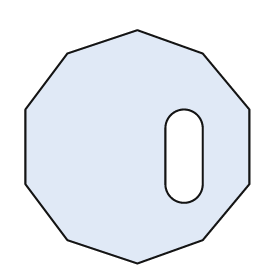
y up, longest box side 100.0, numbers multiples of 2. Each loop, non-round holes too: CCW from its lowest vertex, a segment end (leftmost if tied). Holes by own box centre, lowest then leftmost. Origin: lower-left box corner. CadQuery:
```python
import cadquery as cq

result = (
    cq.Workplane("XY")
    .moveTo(48.0, 0.0)
    .lineTo(76.0, 10.0)
    .lineTo(96.0, 34.0)
    .lineTo(96.0, 66.0)
    .lineTo(76.0, 90.0)
    .lineTo(48.0, 100.0)
    .lineTo(18.0, 90.0)
    .lineTo(0.0, 66.0)
    .lineTo(0.0, 34.0)
    .lineTo(18.0, 10.0)
    .close()
    .moveTo(60.0, 34.0)
    .threePointArc((68.0, 26.0), (76.0, 34.0))
    .lineTo(76.0, 58.0)
    .threePointArc((68.0, 66.0), (60.0, 58.0))
    .close()
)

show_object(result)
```